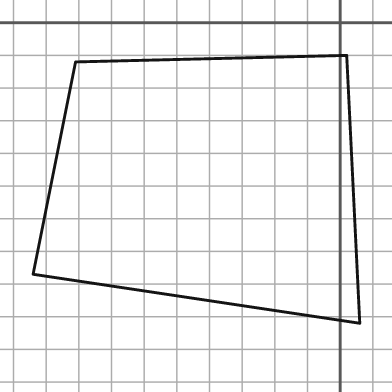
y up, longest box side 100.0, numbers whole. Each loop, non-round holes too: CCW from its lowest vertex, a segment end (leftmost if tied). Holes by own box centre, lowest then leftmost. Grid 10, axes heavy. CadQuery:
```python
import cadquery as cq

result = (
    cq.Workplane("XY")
    .moveTo(6.0, -92.0)
    .lineTo(2.0, -10.0)
    .lineTo(-81.0, -12.0)
    .lineTo(-94.0, -77.0)
    .close()
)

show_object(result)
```